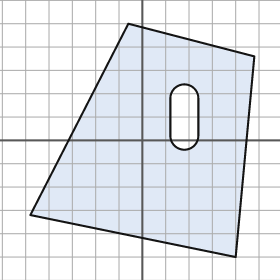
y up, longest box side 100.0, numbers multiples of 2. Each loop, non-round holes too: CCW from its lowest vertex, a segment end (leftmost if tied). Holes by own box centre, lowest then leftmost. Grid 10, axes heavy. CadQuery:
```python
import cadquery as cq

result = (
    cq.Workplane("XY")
    .moveTo(40.0, -50.0)
    .lineTo(48.0, 36.0)
    .lineTo(-6.0, 50.0)
    .lineTo(-48.0, -32.0)
    .close()
    .moveTo(12.0, 2.0)
    .threePointArc((18.0, -4.0), (24.0, 2.0))
    .lineTo(24.0, 18.0)
    .threePointArc((18.0, 24.0), (12.0, 18.0))
    .close()
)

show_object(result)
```